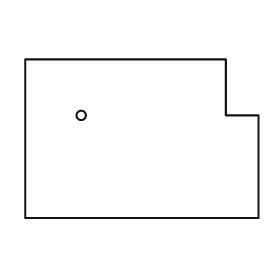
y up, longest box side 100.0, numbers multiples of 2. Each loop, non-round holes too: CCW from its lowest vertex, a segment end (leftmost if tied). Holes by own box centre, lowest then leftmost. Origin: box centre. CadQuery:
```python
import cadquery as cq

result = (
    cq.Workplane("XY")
    .moveTo(-50.0, -34.0)
    .lineTo(50.0, -34.0)
    .lineTo(50.0, 10.0)
    .lineTo(36.0, 10.0)
    .lineTo(36.0, 34.0)
    .lineTo(-50.0, 34.0)
    .close()
    .moveTo(-26.0, 10.0)
    .circle(2.0)
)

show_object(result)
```